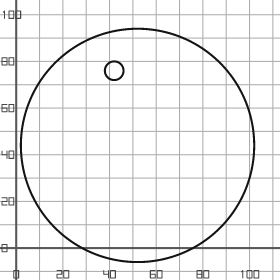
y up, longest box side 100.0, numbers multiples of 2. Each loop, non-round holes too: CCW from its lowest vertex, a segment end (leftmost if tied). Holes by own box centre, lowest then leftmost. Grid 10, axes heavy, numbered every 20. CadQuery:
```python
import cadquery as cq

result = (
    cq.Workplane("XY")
    .moveTo(52.0, 44.0)
    .circle(50.0)
    .moveTo(42.0, 76.0)
    .circle(4.0)
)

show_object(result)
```